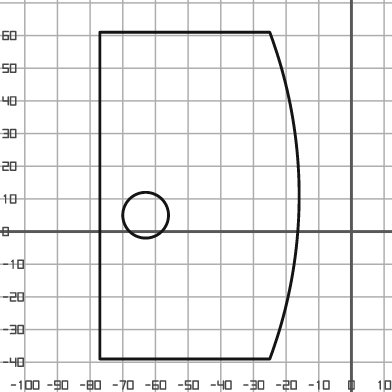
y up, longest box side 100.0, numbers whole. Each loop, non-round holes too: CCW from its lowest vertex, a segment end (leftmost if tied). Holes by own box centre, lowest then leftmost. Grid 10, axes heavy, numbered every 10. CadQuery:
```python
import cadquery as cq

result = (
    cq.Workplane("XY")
    .moveTo(-77.0, -39.0)
    .lineTo(-25.0, -39.0)
    .threePointArc((-16.0, 11.0), (-25.0, 61.0))
    .lineTo(-77.0, 61.0)
    .close()
    .moveTo(-63.0, 5.0)
    .circle(7.0)
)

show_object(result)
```